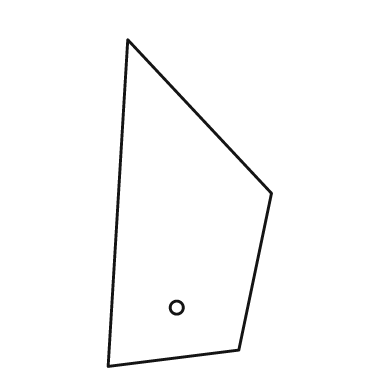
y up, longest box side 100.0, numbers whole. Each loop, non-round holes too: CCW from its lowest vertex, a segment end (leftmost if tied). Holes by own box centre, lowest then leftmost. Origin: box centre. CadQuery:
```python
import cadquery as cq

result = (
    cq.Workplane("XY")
    .moveTo(-25.0, -50.0)
    .lineTo(15.0, -45.0)
    .lineTo(25.0, 3.0)
    .lineTo(-19.0, 50.0)
    .close()
    .moveTo(-4.0, -32.0)
    .circle(2.0)
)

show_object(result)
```